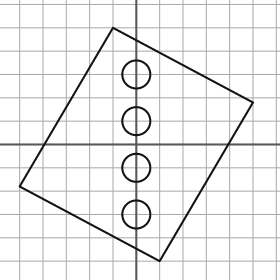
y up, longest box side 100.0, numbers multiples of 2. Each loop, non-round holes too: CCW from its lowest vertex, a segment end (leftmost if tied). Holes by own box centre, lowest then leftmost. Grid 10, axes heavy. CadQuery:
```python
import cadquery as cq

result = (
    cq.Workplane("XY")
    .moveTo(10.0, -50.0)
    .lineTo(50.0, 18.0)
    .lineTo(-10.0, 50.0)
    .lineTo(-50.0, -18.0)
    .close()
    .moveTo(0.0, -30.0)
    .circle(6.0)
    .moveTo(0.0, -10.0)
    .circle(6.0)
    .moveTo(0.0, 10.0)
    .circle(6.0)
    .moveTo(0.0, 30.0)
    .circle(6.0)
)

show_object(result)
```